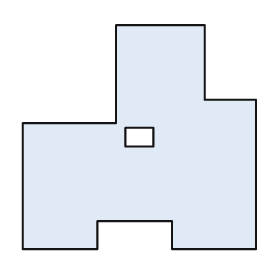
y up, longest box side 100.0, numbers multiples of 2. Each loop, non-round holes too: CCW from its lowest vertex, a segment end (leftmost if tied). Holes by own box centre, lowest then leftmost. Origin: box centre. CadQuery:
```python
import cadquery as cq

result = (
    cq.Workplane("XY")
    .moveTo(-50.0, -48.0)
    .lineTo(-18.0, -48.0)
    .lineTo(-18.0, -36.0)
    .lineTo(14.0, -36.0)
    .lineTo(14.0, -48.0)
    .lineTo(50.0, -48.0)
    .lineTo(50.0, 16.0)
    .lineTo(28.0, 16.0)
    .lineTo(28.0, 48.0)
    .lineTo(-10.0, 48.0)
    .lineTo(-10.0, 6.0)
    .lineTo(-50.0, 6.0)
    .close()
    .moveTo(-6.0, -4.0)
    .lineTo(6.0, -4.0)
    .lineTo(6.0, 4.0)
    .lineTo(-6.0, 4.0)
    .close()
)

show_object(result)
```